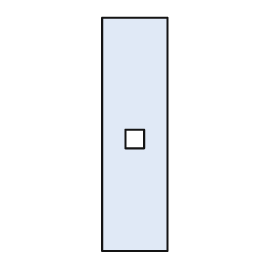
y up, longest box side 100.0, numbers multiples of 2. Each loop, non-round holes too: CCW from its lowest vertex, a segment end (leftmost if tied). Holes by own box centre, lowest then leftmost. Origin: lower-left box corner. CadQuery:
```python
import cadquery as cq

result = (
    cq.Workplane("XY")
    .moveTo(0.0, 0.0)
    .lineTo(28.0, 0.0)
    .lineTo(28.0, 100.0)
    .lineTo(0.0, 100.0)
    .close()
    .moveTo(10.0, 44.0)
    .lineTo(18.0, 44.0)
    .lineTo(18.0, 52.0)
    .lineTo(10.0, 52.0)
    .close()
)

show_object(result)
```